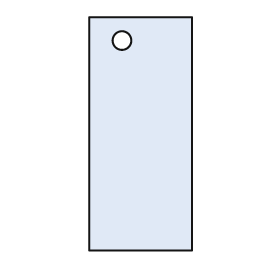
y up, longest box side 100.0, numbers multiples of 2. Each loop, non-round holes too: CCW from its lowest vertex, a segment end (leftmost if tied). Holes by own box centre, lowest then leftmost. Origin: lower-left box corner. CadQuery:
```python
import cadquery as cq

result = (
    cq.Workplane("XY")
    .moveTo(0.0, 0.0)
    .lineTo(44.0, 0.0)
    .lineTo(44.0, 100.0)
    .lineTo(0.0, 100.0)
    .close()
    .moveTo(14.0, 90.0)
    .circle(4.0)
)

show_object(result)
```